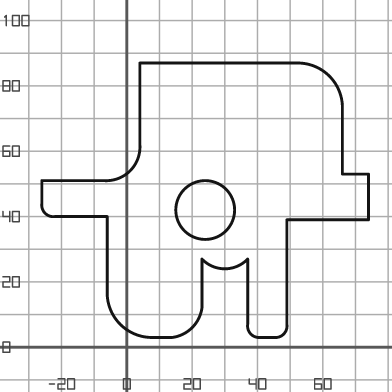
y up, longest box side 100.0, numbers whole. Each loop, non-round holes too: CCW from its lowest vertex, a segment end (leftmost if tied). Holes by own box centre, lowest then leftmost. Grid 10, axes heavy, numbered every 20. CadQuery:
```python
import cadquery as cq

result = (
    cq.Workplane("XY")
    .moveTo(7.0, 3.0)
    .lineTo(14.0, 3.0)
    .threePointArc((20.0, 6.0), (23.0, 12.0))
    .lineTo(23.0, 27.0)
    .threePointArc((30.0, 24.0), (37.0, 27.0))
    .lineTo(37.0, 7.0)
    .threePointArc((38.0, 4.0), (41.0, 3.0))
    .lineTo(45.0, 3.0)
    .threePointArc((48.0, 4.0), (49.0, 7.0))
    .lineTo(49.0, 39.0)
    .lineTo(74.0, 39.0)
    .lineTo(74.0, 53.0)
    .lineTo(66.0, 53.0)
    .lineTo(66.0, 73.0)
    .threePointArc((62.0, 83.0), (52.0, 87.0))
    .lineTo(4.0, 87.0)
    .lineTo(4.0, 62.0)
    .threePointArc((1.0, 54.0), (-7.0, 51.0))
    .lineTo(-26.0, 51.0)
    .lineTo(-26.0, 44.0)
    .threePointArc((-25.0, 41.0), (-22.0, 40.0))
    .lineTo(-6.0, 40.0)
    .lineTo(-6.0, 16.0)
    .threePointArc((-2.0, 7.0), (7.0, 3.0))
    .close()
    .moveTo(24.0, 42.0)
    .circle(9.0)
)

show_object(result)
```